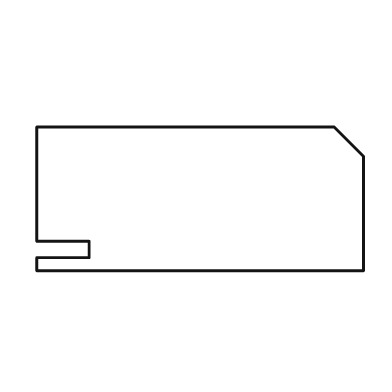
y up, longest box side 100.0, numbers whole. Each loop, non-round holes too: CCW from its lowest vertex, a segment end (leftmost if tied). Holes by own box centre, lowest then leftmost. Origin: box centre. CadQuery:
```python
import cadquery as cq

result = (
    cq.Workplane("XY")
    .moveTo(-50.0, -22.0)
    .lineTo(50.0, -22.0)
    .lineTo(50.0, 13.0)
    .lineTo(41.0, 22.0)
    .lineTo(-50.0, 22.0)
    .lineTo(-50.0, -13.0)
    .lineTo(-34.0, -13.0)
    .lineTo(-34.0, -18.0)
    .lineTo(-50.0, -18.0)
    .close()
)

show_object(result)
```